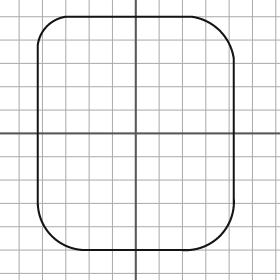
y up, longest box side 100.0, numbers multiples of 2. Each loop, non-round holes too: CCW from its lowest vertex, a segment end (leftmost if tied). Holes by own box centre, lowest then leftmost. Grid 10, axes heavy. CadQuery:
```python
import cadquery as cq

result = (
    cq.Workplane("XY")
    .moveTo(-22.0, -50.0)
    .lineTo(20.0, -50.0)
    .threePointArc((36.0, -44.0), (42.0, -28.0))
    .lineTo(42.0, 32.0)
    .threePointArc((36.0, 44.0), (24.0, 50.0))
    .lineTo(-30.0, 50.0)
    .threePointArc((-38.0, 46.0), (-42.0, 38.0))
    .lineTo(-42.0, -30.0)
    .threePointArc((-36.0, -44.0), (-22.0, -50.0))
    .close()
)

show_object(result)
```